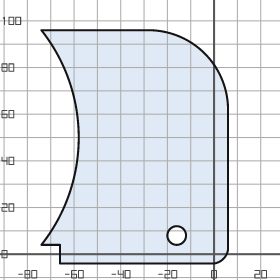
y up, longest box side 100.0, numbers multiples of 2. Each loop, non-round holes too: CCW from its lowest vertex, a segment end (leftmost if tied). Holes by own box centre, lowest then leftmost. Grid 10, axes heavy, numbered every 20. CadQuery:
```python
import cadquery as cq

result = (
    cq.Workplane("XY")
    .moveTo(-66.0, -4.0)
    .lineTo(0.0, -4.0)
    .threePointArc((4.0, -2.0), (6.0, 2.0))
    .lineTo(6.0, 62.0)
    .threePointArc((-4.0, 86.0), (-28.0, 96.0))
    .lineTo(-74.0, 96.0)
    .threePointArc((-58.0, 50.0), (-74.0, 4.0))
    .lineTo(-66.0, 4.0)
    .close()
    .moveTo(-16.0, 8.0)
    .circle(4.0)
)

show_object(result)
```